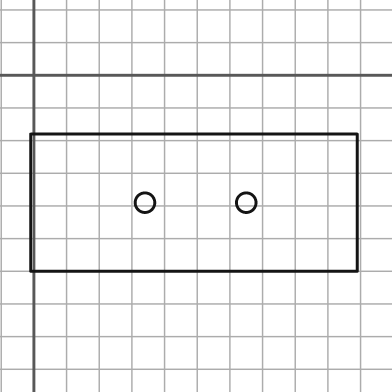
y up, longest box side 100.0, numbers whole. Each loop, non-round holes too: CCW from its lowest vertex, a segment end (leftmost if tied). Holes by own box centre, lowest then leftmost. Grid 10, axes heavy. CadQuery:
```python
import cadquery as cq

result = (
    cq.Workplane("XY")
    .moveTo(-1.0, -60.0)
    .lineTo(99.0, -60.0)
    .lineTo(99.0, -18.0)
    .lineTo(-1.0, -18.0)
    .close()
    .moveTo(34.0, -39.0)
    .circle(3.0)
    .moveTo(65.0, -39.0)
    .circle(3.0)
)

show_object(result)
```